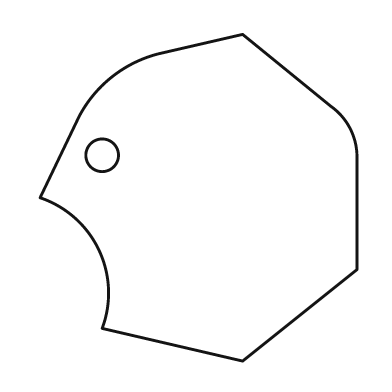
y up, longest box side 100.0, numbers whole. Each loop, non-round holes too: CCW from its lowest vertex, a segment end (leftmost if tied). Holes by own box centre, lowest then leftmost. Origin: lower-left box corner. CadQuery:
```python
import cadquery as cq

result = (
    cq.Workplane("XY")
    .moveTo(62.0, 0.0)
    .lineTo(97.0, 28.0)
    .lineTo(97.0, 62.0)
    .threePointArc((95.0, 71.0), (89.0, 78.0))
    .lineTo(62.0, 100.0)
    .lineTo(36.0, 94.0)
    .threePointArc((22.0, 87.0), (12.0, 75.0))
    .lineTo(0.0, 50.0)
    .threePointArc((18.0, 34.0), (19.0, 10.0))
    .close()
    .moveTo(19.0, 63.0)
    .circle(5.0)
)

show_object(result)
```